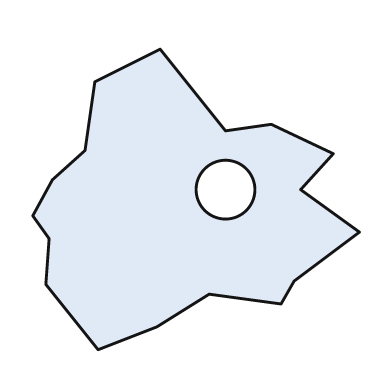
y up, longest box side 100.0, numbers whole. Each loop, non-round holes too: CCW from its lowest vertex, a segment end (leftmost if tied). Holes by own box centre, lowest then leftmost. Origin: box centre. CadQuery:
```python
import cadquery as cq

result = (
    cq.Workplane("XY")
    .moveTo(-30.0, -46.0)
    .lineTo(-12.0, -39.0)
    .lineTo(4.0, -29.0)
    .lineTo(26.0, -32.0)
    .lineTo(30.0, -25.0)
    .lineTo(50.0, -10.0)
    .lineTo(32.0, 3.0)
    .lineTo(42.0, 14.0)
    .lineTo(23.0, 23.0)
    .lineTo(9.0, 21.0)
    .lineTo(-11.0, 46.0)
    .lineTo(-31.0, 36.0)
    .lineTo(-34.0, 15.0)
    .lineTo(-44.0, 6.0)
    .lineTo(-50.0, -5.0)
    .lineTo(-45.0, -12.0)
    .lineTo(-46.0, -26.0)
    .close()
    .moveTo(9.0, 3.0)
    .circle(9.0)
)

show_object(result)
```